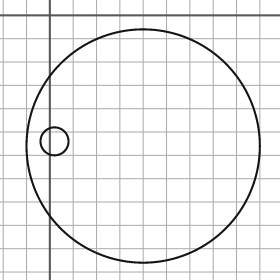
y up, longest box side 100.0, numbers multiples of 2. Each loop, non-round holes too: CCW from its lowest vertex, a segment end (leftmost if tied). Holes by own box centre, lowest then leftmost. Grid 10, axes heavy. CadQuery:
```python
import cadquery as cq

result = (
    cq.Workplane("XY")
    .moveTo(40.0, -56.0)
    .circle(50.0)
    .moveTo(2.0, -54.0)
    .circle(6.0)
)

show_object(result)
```